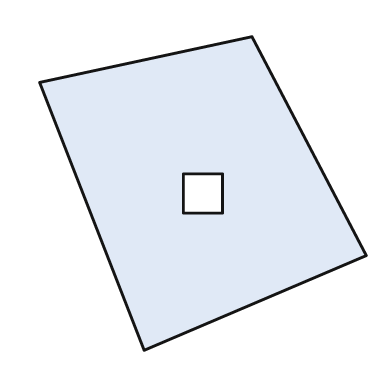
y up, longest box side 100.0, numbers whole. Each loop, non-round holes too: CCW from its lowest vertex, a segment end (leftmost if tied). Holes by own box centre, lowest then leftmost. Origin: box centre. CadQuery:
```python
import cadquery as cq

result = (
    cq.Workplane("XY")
    .moveTo(-18.0, -48.0)
    .lineTo(50.0, -19.0)
    .lineTo(15.0, 48.0)
    .lineTo(-50.0, 34.0)
    .close()
    .moveTo(-6.0, -6.0)
    .lineTo(6.0, -6.0)
    .lineTo(6.0, 6.0)
    .lineTo(-6.0, 6.0)
    .close()
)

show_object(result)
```